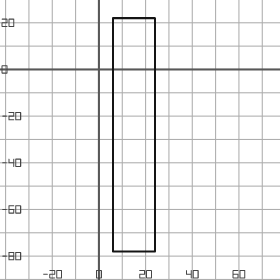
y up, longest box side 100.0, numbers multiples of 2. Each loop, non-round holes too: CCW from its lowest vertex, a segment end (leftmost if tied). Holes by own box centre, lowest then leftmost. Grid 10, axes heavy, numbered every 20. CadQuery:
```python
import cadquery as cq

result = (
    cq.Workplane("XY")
    .moveTo(6.0, -78.0)
    .lineTo(24.0, -78.0)
    .lineTo(24.0, 22.0)
    .lineTo(6.0, 22.0)
    .close()
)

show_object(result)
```